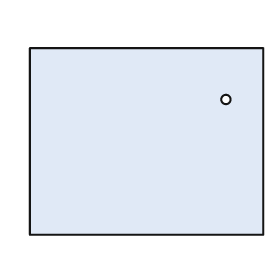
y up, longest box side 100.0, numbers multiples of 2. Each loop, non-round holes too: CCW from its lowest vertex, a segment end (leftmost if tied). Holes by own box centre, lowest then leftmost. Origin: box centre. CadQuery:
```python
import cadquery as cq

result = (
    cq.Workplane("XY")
    .moveTo(-50.0, -40.0)
    .lineTo(50.0, -40.0)
    .lineTo(50.0, 40.0)
    .lineTo(-50.0, 40.0)
    .close()
    .moveTo(34.0, 18.0)
    .circle(2.0)
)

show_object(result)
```